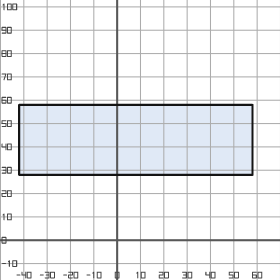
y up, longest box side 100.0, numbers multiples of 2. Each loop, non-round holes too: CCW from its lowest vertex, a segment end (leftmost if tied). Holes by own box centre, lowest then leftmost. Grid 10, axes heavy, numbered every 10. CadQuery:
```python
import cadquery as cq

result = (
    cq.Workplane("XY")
    .moveTo(-42.0, 28.0)
    .lineTo(58.0, 28.0)
    .lineTo(58.0, 58.0)
    .lineTo(-42.0, 58.0)
    .close()
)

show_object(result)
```